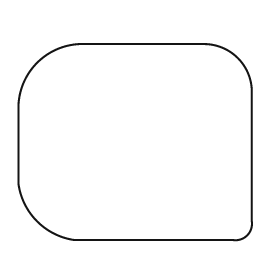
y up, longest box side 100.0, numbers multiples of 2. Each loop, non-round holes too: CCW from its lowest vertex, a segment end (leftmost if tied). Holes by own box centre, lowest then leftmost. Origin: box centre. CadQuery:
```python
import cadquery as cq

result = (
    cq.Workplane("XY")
    .moveTo(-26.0, -42.0)
    .lineTo(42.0, -42.0)
    .threePointArc((48.0, -40.0), (50.0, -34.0))
    .lineTo(50.0, 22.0)
    .threePointArc((44.0, 36.0), (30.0, 42.0))
    .lineTo(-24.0, 42.0)
    .threePointArc((-42.0, 34.0), (-50.0, 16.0))
    .lineTo(-50.0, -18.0)
    .threePointArc((-42.0, -34.0), (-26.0, -42.0))
    .close()
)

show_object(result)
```